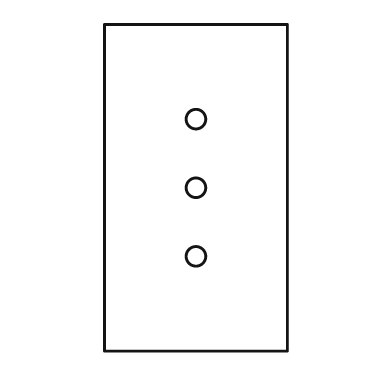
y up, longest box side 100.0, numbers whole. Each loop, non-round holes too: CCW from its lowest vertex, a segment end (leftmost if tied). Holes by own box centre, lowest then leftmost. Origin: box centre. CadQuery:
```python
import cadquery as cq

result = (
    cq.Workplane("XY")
    .moveTo(-28.0, -50.0)
    .lineTo(28.0, -50.0)
    .lineTo(28.0, 50.0)
    .lineTo(-28.0, 50.0)
    .close()
    .moveTo(0.0, -21.0)
    .circle(3.0)
    .moveTo(0.0, 0.0)
    .circle(3.0)
    .moveTo(0.0, 21.0)
    .circle(3.0)
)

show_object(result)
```